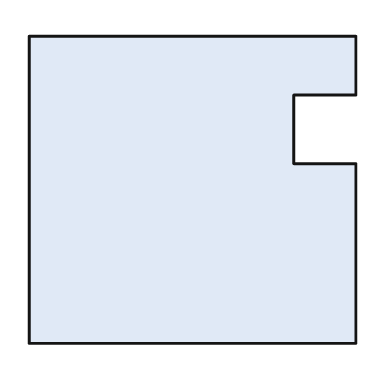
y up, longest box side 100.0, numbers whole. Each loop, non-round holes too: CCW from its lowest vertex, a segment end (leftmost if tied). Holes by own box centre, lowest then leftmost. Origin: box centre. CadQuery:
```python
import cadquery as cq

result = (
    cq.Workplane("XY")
    .moveTo(-50.0, -47.0)
    .lineTo(50.0, -47.0)
    .lineTo(50.0, 8.0)
    .lineTo(31.0, 8.0)
    .lineTo(31.0, 29.0)
    .lineTo(50.0, 29.0)
    .lineTo(50.0, 47.0)
    .lineTo(-50.0, 47.0)
    .close()
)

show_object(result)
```